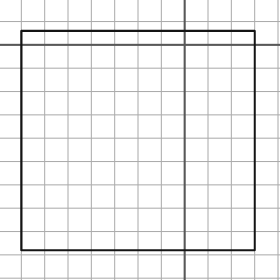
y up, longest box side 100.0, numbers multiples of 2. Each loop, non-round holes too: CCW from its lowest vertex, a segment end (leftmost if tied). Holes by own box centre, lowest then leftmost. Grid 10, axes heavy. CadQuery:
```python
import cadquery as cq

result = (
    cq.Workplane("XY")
    .moveTo(-70.0, -88.0)
    .lineTo(30.0, -88.0)
    .lineTo(30.0, 6.0)
    .lineTo(-70.0, 6.0)
    .close()
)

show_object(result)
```